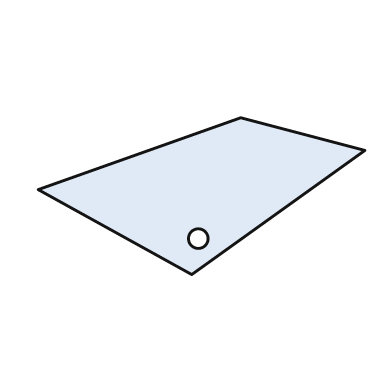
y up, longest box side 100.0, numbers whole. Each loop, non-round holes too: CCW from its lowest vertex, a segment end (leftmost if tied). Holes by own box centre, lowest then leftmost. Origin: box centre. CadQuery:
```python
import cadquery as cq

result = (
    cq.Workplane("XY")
    .moveTo(-3.0, -24.0)
    .lineTo(50.0, 14.0)
    .lineTo(12.0, 24.0)
    .lineTo(-50.0, 2.0)
    .close()
    .moveTo(-1.0, -13.0)
    .circle(3.0)
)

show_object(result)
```